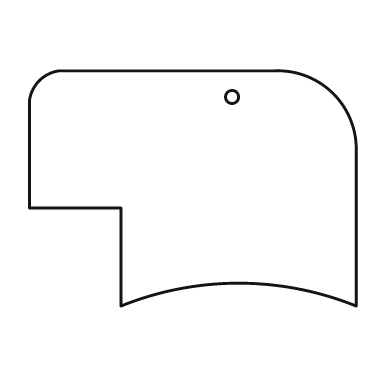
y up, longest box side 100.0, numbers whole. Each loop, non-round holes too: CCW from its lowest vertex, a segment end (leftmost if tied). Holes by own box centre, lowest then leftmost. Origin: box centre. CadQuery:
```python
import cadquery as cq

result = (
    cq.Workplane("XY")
    .moveTo(-22.0, -36.0)
    .threePointArc((14.0, -29.0), (50.0, -36.0))
    .lineTo(50.0, 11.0)
    .threePointArc((43.0, 29.0), (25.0, 36.0))
    .lineTo(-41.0, 36.0)
    .threePointArc((-47.0, 33.0), (-50.0, 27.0))
    .lineTo(-50.0, -6.0)
    .lineTo(-22.0, -6.0)
    .close()
    .moveTo(12.0, 28.0)
    .circle(2.0)
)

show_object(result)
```